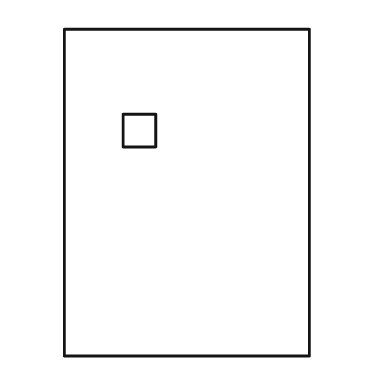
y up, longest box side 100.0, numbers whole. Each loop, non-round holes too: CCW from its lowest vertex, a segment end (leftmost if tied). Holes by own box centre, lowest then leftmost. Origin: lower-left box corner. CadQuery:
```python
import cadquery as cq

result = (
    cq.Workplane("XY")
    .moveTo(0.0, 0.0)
    .lineTo(75.0, 0.0)
    .lineTo(75.0, 100.0)
    .lineTo(0.0, 100.0)
    .close()
    .moveTo(18.0, 64.0)
    .lineTo(28.0, 64.0)
    .lineTo(28.0, 74.0)
    .lineTo(18.0, 74.0)
    .close()
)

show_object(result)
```